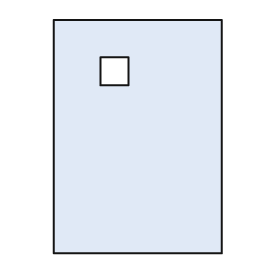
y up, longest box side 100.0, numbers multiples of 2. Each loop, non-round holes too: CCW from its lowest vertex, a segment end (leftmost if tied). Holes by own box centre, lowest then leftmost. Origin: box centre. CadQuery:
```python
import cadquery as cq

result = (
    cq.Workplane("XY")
    .moveTo(-36.0, -50.0)
    .lineTo(36.0, -50.0)
    .lineTo(36.0, 50.0)
    .lineTo(-36.0, 50.0)
    .close()
    .moveTo(-16.0, 22.0)
    .lineTo(-4.0, 22.0)
    .lineTo(-4.0, 34.0)
    .lineTo(-16.0, 34.0)
    .close()
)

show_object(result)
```